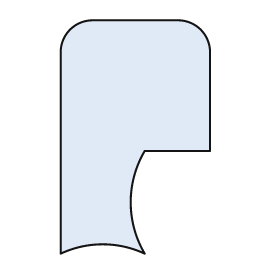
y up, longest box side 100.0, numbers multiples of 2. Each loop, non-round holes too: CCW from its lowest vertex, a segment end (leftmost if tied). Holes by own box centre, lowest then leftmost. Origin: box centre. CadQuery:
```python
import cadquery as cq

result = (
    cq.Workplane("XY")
    .moveTo(-32.0, -50.0)
    .threePointArc((-14.0, -46.0), (4.0, -50.0))
    .threePointArc((-2.0, -28.0), (4.0, -6.0))
    .lineTo(32.0, -6.0)
    .lineTo(32.0, 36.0)
    .threePointArc((28.0, 46.0), (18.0, 50.0))
    .lineTo(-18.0, 50.0)
    .threePointArc((-28.0, 46.0), (-32.0, 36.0))
    .close()
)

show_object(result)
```